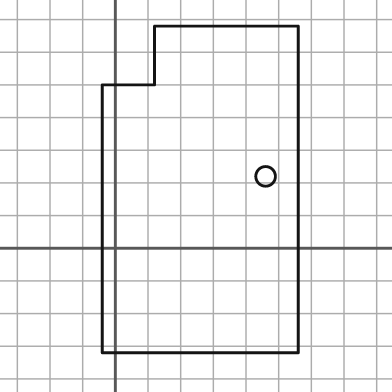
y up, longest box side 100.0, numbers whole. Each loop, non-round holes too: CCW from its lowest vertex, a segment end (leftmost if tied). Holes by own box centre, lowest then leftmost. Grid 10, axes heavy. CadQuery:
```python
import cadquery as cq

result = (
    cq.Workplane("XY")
    .moveTo(-4.0, -32.0)
    .lineTo(56.0, -32.0)
    .lineTo(56.0, 68.0)
    .lineTo(12.0, 68.0)
    .lineTo(12.0, 50.0)
    .lineTo(-4.0, 50.0)
    .close()
    .moveTo(46.0, 22.0)
    .circle(3.0)
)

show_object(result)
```